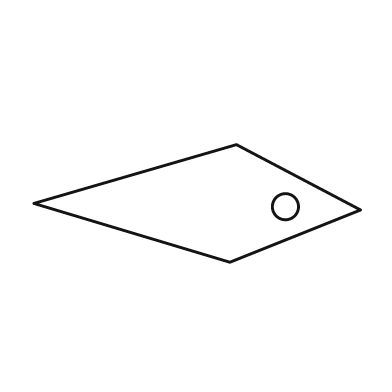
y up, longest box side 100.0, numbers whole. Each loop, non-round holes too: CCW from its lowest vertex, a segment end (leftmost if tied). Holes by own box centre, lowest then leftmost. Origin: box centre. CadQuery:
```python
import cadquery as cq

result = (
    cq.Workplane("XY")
    .moveTo(10.0, -18.0)
    .lineTo(50.0, -2.0)
    .lineTo(12.0, 18.0)
    .lineTo(-50.0, 0.0)
    .close()
    .moveTo(27.0, -1.0)
    .circle(4.0)
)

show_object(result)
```